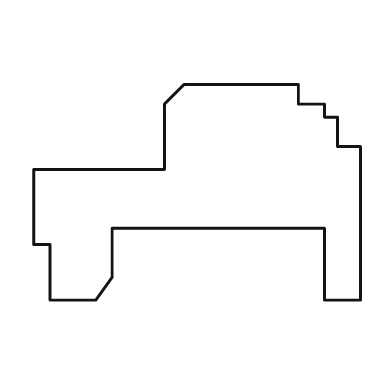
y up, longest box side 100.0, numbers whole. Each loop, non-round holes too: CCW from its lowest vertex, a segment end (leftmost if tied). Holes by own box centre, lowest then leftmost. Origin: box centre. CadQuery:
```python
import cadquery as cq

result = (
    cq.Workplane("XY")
    .moveTo(-45.0, -33.0)
    .lineTo(-31.0, -33.0)
    .lineTo(-26.0, -26.0)
    .lineTo(-26.0, -11.0)
    .lineTo(39.0, -11.0)
    .lineTo(39.0, -33.0)
    .lineTo(50.0, -33.0)
    .lineTo(50.0, 14.0)
    .lineTo(43.0, 14.0)
    .lineTo(43.0, 23.0)
    .lineTo(39.0, 23.0)
    .lineTo(39.0, 27.0)
    .lineTo(31.0, 27.0)
    .lineTo(31.0, 33.0)
    .lineTo(-4.0, 33.0)
    .lineTo(-10.0, 27.0)
    .lineTo(-10.0, 7.0)
    .lineTo(-50.0, 7.0)
    .lineTo(-50.0, -16.0)
    .lineTo(-45.0, -16.0)
    .close()
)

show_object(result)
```